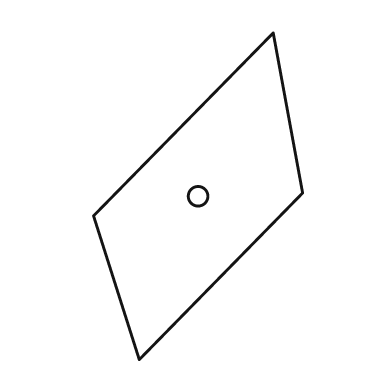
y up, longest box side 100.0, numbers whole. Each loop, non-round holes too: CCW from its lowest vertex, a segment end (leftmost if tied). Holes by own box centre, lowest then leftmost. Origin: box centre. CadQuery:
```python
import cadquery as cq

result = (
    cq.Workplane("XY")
    .moveTo(-18.0, -50.0)
    .lineTo(32.0, 1.0)
    .lineTo(23.0, 50.0)
    .lineTo(-32.0, -6.0)
    .close()
    .moveTo(0.0, 0.0)
    .circle(3.0)
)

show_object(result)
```